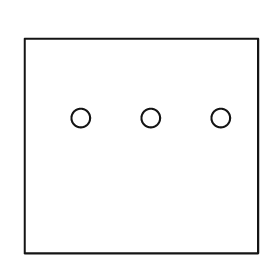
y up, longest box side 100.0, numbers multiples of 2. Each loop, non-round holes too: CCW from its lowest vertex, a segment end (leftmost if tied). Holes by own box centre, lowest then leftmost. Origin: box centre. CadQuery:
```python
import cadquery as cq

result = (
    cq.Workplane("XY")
    .moveTo(-50.0, -46.0)
    .lineTo(50.0, -46.0)
    .lineTo(50.0, 46.0)
    .lineTo(-50.0, 46.0)
    .close()
    .moveTo(-26.0, 12.0)
    .circle(4.0)
    .moveTo(4.0, 12.0)
    .circle(4.0)
    .moveTo(34.0, 12.0)
    .circle(4.0)
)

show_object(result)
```